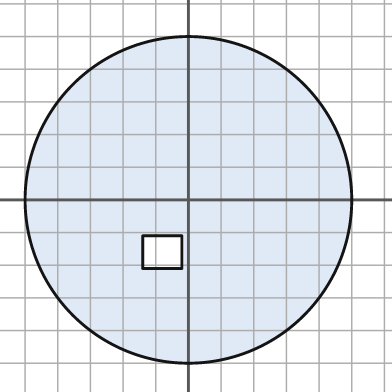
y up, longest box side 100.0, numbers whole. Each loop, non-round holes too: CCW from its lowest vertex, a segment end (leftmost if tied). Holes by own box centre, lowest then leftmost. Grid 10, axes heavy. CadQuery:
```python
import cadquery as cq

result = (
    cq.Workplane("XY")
    .moveTo(0.0, 0.0)
    .circle(50.0)
    .moveTo(-14.0, -21.0)
    .lineTo(-2.0, -21.0)
    .lineTo(-2.0, -11.0)
    .lineTo(-14.0, -11.0)
    .close()
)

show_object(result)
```